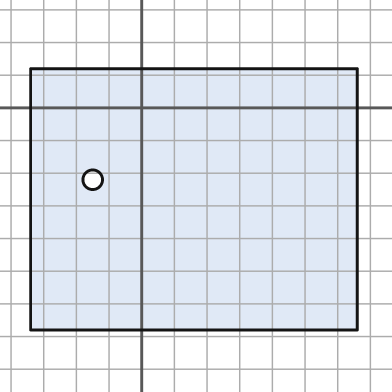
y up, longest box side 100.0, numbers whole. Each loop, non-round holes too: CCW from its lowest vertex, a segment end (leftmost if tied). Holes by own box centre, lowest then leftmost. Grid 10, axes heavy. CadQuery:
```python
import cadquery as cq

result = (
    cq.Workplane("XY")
    .moveTo(-34.0, -68.0)
    .lineTo(66.0, -68.0)
    .lineTo(66.0, 12.0)
    .lineTo(-34.0, 12.0)
    .close()
    .moveTo(-15.0, -22.0)
    .circle(3.0)
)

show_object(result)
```